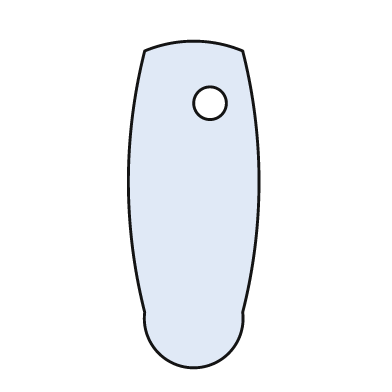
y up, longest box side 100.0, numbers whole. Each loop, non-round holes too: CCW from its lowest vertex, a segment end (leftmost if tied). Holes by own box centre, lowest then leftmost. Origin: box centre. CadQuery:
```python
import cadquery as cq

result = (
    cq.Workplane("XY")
    .moveTo(-15.0, -33.0)
    .threePointArc((0.0, -50.0), (15.0, -33.0))
    .threePointArc((20.0, 7.0), (15.0, 47.0))
    .threePointArc((0.0, 50.0), (-15.0, 47.0))
    .threePointArc((-20.0, 7.0), (-15.0, -33.0))
    .close()
    .moveTo(5.0, 31.0)
    .circle(5.0)
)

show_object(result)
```